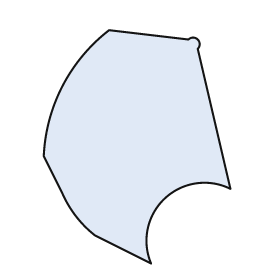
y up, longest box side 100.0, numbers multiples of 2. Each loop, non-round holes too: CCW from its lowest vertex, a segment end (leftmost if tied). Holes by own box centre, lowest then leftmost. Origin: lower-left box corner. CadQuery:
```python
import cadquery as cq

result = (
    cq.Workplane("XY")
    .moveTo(46.0, 0.0)
    .threePointArc((52.0, 28.0), (80.0, 32.0))
    .lineTo(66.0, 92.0)
    .threePointArc((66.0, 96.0), (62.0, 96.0))
    .lineTo(28.0, 100.0)
    .threePointArc((8.0, 76.0), (0.0, 46.0))
    .lineTo(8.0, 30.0)
    .threePointArc((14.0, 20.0), (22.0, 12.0))
    .close()
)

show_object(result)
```